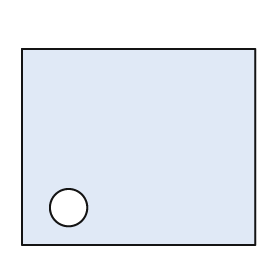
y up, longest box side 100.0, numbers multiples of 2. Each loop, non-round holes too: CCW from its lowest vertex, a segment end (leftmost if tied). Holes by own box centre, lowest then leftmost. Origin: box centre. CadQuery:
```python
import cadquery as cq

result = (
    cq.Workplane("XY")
    .moveTo(-50.0, -42.0)
    .lineTo(50.0, -42.0)
    .lineTo(50.0, 42.0)
    .lineTo(-50.0, 42.0)
    .close()
    .moveTo(-30.0, -26.0)
    .circle(8.0)
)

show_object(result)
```